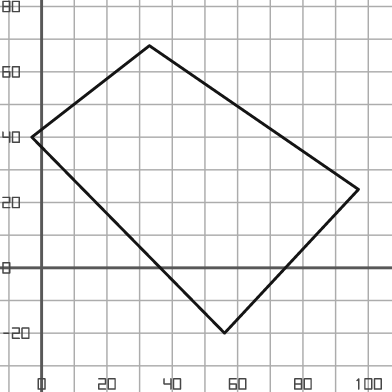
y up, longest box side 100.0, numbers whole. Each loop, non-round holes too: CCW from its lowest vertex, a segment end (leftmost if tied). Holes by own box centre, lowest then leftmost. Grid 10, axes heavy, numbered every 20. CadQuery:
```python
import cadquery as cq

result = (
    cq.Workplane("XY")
    .moveTo(56.0, -20.0)
    .lineTo(97.0, 24.0)
    .lineTo(33.0, 68.0)
    .lineTo(-3.0, 40.0)
    .close()
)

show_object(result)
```